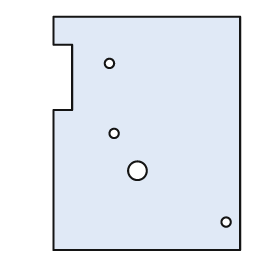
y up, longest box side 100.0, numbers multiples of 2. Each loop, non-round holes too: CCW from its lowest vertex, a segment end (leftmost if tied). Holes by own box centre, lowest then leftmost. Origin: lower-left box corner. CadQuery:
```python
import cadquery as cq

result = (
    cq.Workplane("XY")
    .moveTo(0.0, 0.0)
    .lineTo(80.0, 0.0)
    .lineTo(80.0, 100.0)
    .lineTo(0.0, 100.0)
    .lineTo(0.0, 88.0)
    .lineTo(8.0, 88.0)
    .lineTo(8.0, 60.0)
    .lineTo(0.0, 60.0)
    .close()
    .moveTo(74.0, 12.0)
    .circle(2.0)
    .moveTo(36.0, 34.0)
    .circle(4.0)
    .moveTo(26.0, 50.0)
    .circle(2.0)
    .moveTo(24.0, 80.0)
    .circle(2.0)
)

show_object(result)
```